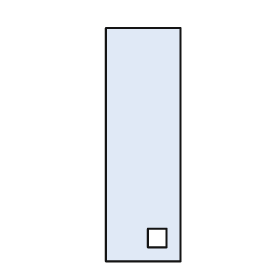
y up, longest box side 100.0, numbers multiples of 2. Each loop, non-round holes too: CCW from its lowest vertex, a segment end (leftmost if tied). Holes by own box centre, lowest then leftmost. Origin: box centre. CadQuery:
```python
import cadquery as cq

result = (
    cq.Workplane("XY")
    .moveTo(-16.0, -50.0)
    .lineTo(16.0, -50.0)
    .lineTo(16.0, 50.0)
    .lineTo(-16.0, 50.0)
    .close()
    .moveTo(2.0, -44.0)
    .lineTo(10.0, -44.0)
    .lineTo(10.0, -36.0)
    .lineTo(2.0, -36.0)
    .close()
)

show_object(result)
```